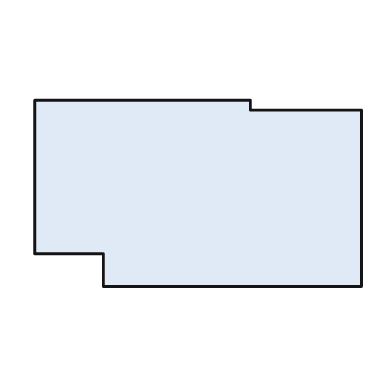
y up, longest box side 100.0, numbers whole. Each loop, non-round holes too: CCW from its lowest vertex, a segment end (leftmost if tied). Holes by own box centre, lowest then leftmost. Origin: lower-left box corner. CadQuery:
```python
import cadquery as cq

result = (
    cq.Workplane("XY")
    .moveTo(21.0, 0.0)
    .lineTo(100.0, 0.0)
    .lineTo(100.0, 54.0)
    .lineTo(66.0, 54.0)
    .lineTo(66.0, 57.0)
    .lineTo(0.0, 57.0)
    .lineTo(0.0, 10.0)
    .lineTo(21.0, 10.0)
    .close()
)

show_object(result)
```